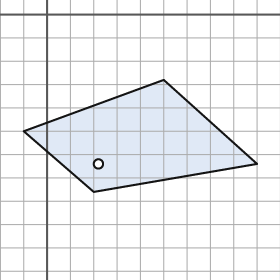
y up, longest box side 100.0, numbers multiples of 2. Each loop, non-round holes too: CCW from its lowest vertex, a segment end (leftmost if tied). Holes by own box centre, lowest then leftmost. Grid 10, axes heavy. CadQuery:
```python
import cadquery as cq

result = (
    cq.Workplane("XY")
    .moveTo(20.0, -76.0)
    .lineTo(90.0, -64.0)
    .lineTo(50.0, -28.0)
    .lineTo(-10.0, -50.0)
    .close()
    .moveTo(22.0, -64.0)
    .circle(2.0)
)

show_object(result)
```